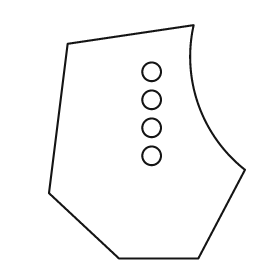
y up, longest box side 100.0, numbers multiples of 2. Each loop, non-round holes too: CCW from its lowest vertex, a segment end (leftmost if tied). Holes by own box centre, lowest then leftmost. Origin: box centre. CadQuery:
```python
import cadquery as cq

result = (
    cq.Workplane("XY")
    .moveTo(-12.0, -50.0)
    .lineTo(22.0, -50.0)
    .lineTo(42.0, -12.0)
    .threePointArc((22.0, 16.0), (20.0, 50.0))
    .lineTo(-34.0, 42.0)
    .lineTo(-42.0, -22.0)
    .close()
    .moveTo(2.0, -6.0)
    .circle(4.0)
    .moveTo(2.0, 6.0)
    .circle(4.0)
    .moveTo(2.0, 18.0)
    .circle(4.0)
    .moveTo(2.0, 30.0)
    .circle(4.0)
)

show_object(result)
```